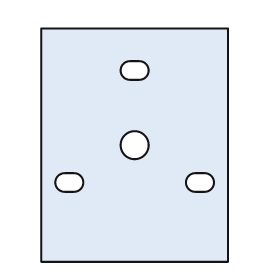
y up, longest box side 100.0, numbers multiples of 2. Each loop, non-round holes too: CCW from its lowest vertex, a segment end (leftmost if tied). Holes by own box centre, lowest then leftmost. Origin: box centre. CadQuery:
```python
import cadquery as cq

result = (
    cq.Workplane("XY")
    .moveTo(-40.0, -50.0)
    .lineTo(40.0, -50.0)
    .lineTo(40.0, 50.0)
    .lineTo(-40.0, 50.0)
    .close()
    .moveTo(-30.0, -20.0)
    .lineTo(-26.0, -20.0)
    .threePointArc((-22.0, -16.0), (-26.0, -12.0))
    .lineTo(-30.0, -12.0)
    .threePointArc((-34.0, -16.0), (-30.0, -20.0))
    .close()
    .moveTo(26.0, -20.0)
    .lineTo(30.0, -20.0)
    .threePointArc((34.0, -16.0), (30.0, -12.0))
    .lineTo(26.0, -12.0)
    .threePointArc((22.0, -16.0), (26.0, -20.0))
    .close()
    .moveTo(0.0, 0.0)
    .circle(6.0)
    .moveTo(-2.0, 28.0)
    .lineTo(2.0, 28.0)
    .threePointArc((6.0, 32.0), (2.0, 36.0))
    .lineTo(-2.0, 36.0)
    .threePointArc((-6.0, 32.0), (-2.0, 28.0))
    .close()
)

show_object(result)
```